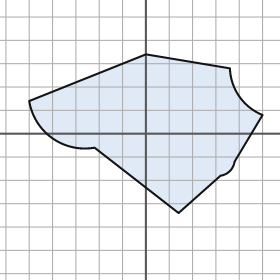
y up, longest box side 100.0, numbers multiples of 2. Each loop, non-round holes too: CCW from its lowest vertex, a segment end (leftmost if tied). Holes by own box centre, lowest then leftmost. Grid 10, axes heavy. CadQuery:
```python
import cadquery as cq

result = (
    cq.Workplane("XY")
    .moveTo(14.0, -34.0)
    .lineTo(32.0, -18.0)
    .threePointArc((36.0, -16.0), (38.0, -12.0))
    .lineTo(50.0, 8.0)
    .threePointArc((40.0, 16.0), (36.0, 28.0))
    .lineTo(0.0, 34.0)
    .lineTo(-50.0, 14.0)
    .threePointArc((-40.0, -2.0), (-22.0, -6.0))
    .close()
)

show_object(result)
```